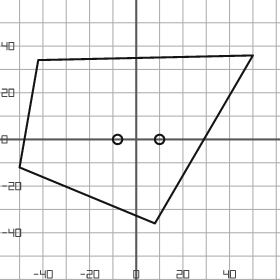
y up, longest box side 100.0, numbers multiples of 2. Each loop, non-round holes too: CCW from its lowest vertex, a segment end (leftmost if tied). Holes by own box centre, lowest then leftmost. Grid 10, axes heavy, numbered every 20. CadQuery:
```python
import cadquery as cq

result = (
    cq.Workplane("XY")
    .moveTo(8.0, -36.0)
    .lineTo(50.0, 36.0)
    .lineTo(-42.0, 34.0)
    .lineTo(-50.0, -12.0)
    .close()
    .moveTo(-8.0, 0.0)
    .circle(2.0)
    .moveTo(10.0, 0.0)
    .circle(2.0)
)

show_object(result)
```